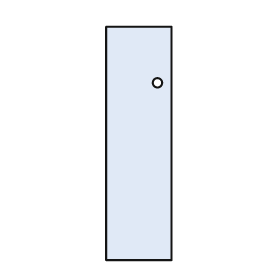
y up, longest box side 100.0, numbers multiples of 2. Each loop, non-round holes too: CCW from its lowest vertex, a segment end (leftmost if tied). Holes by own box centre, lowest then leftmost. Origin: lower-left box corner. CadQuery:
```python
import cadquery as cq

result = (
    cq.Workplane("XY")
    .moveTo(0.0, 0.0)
    .lineTo(28.0, 0.0)
    .lineTo(28.0, 100.0)
    .lineTo(0.0, 100.0)
    .close()
    .moveTo(22.0, 76.0)
    .circle(2.0)
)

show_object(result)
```